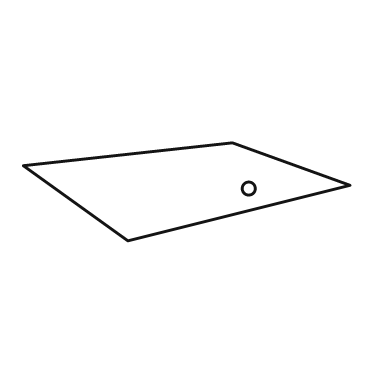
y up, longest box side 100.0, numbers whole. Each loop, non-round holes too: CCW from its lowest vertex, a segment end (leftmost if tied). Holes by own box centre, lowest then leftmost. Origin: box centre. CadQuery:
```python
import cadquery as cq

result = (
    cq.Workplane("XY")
    .moveTo(-18.0, -15.0)
    .lineTo(50.0, 2.0)
    .lineTo(14.0, 15.0)
    .lineTo(-50.0, 8.0)
    .close()
    .moveTo(19.0, 1.0)
    .circle(2.0)
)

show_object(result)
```